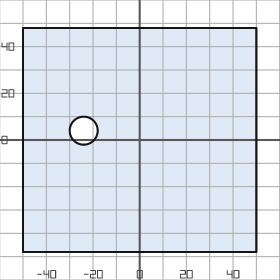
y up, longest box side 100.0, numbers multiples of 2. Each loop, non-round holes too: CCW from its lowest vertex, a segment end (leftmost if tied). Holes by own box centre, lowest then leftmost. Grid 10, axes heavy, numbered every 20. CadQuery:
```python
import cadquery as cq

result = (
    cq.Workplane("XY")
    .moveTo(-50.0, -48.0)
    .lineTo(50.0, -48.0)
    .lineTo(50.0, 48.0)
    .lineTo(-50.0, 48.0)
    .close()
    .moveTo(-24.0, 4.0)
    .circle(6.0)
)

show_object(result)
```